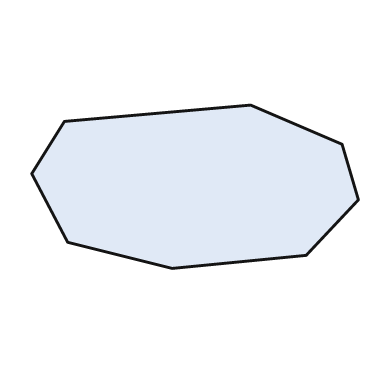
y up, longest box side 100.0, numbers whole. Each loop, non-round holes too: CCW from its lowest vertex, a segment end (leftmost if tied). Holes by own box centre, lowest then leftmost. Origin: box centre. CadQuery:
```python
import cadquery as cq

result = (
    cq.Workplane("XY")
    .moveTo(-7.0, -25.0)
    .lineTo(34.0, -21.0)
    .lineTo(50.0, -4.0)
    .lineTo(45.0, 13.0)
    .lineTo(17.0, 25.0)
    .lineTo(-40.0, 20.0)
    .lineTo(-50.0, 4.0)
    .lineTo(-39.0, -17.0)
    .close()
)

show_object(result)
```